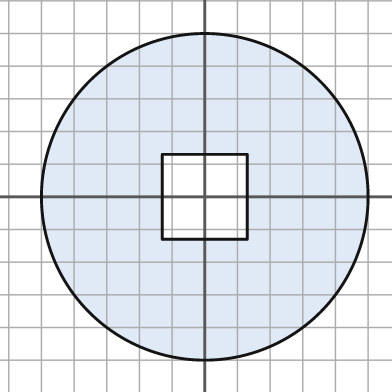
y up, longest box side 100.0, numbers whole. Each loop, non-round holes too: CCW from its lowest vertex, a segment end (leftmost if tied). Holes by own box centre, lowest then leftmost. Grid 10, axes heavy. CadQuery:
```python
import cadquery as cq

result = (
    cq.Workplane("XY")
    .moveTo(0.0, 0.0)
    .circle(50.0)
    .moveTo(-13.0, -13.0)
    .lineTo(13.0, -13.0)
    .lineTo(13.0, 13.0)
    .lineTo(-13.0, 13.0)
    .close()
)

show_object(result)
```